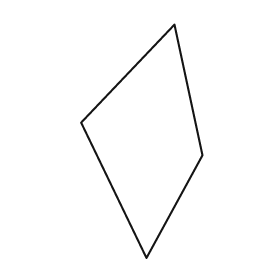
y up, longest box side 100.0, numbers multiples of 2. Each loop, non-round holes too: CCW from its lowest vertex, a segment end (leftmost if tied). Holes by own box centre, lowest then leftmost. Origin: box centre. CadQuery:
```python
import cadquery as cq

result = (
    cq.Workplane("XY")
    .moveTo(2.0, -50.0)
    .lineTo(26.0, -6.0)
    .lineTo(14.0, 50.0)
    .lineTo(-26.0, 8.0)
    .close()
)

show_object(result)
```